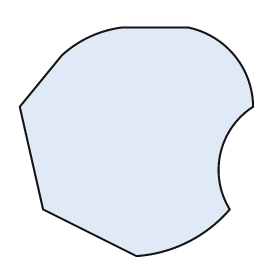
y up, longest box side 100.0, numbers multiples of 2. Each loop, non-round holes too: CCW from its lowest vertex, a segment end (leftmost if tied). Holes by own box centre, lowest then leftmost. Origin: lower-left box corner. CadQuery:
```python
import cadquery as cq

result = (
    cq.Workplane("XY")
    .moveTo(50.0, 0.0)
    .threePointArc((72.0, 6.0), (90.0, 20.0))
    .threePointArc((86.0, 44.0), (100.0, 64.0))
    .threePointArc((92.0, 86.0), (72.0, 98.0))
    .lineTo(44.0, 98.0)
    .threePointArc((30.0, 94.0), (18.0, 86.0))
    .lineTo(0.0, 64.0)
    .lineTo(10.0, 20.0)
    .close()
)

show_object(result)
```